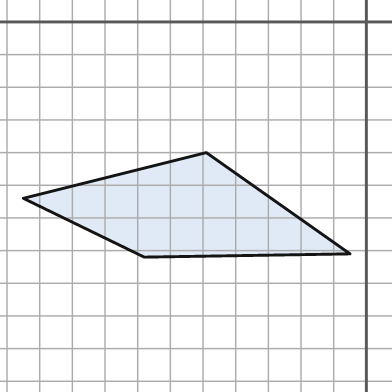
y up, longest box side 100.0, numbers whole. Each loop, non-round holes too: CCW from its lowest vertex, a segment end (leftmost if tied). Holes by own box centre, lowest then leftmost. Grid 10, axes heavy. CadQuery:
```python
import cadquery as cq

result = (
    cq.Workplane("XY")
    .moveTo(-68.0, -72.0)
    .lineTo(-5.0, -71.0)
    .lineTo(-49.0, -40.0)
    .lineTo(-105.0, -54.0)
    .close()
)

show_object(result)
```